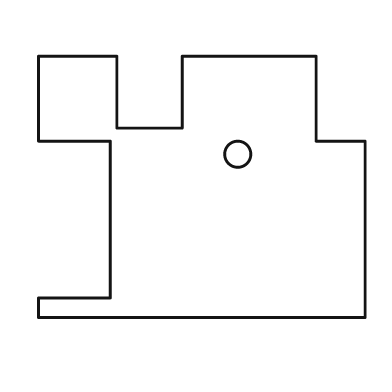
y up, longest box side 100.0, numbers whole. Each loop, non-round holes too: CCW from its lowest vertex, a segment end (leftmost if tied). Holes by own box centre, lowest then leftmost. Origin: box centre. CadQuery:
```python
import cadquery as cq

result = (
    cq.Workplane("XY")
    .moveTo(-50.0, -40.0)
    .lineTo(50.0, -40.0)
    .lineTo(50.0, 14.0)
    .lineTo(35.0, 14.0)
    .lineTo(35.0, 40.0)
    .lineTo(-6.0, 40.0)
    .lineTo(-6.0, 18.0)
    .lineTo(-26.0, 18.0)
    .lineTo(-26.0, 40.0)
    .lineTo(-50.0, 40.0)
    .lineTo(-50.0, 14.0)
    .lineTo(-28.0, 14.0)
    .lineTo(-28.0, -34.0)
    .lineTo(-50.0, -34.0)
    .close()
    .moveTo(11.0, 10.0)
    .circle(4.0)
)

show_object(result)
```